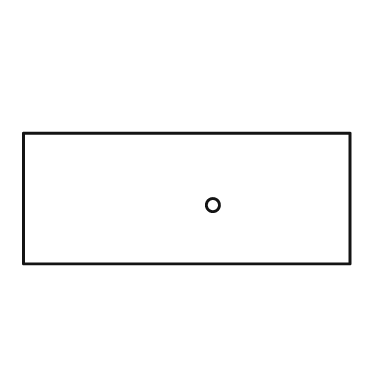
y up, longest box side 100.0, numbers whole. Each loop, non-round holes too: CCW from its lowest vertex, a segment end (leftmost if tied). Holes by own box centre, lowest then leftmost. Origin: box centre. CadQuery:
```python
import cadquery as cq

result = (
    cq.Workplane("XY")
    .moveTo(-50.0, -20.0)
    .lineTo(50.0, -20.0)
    .lineTo(50.0, 20.0)
    .lineTo(-50.0, 20.0)
    .close()
    .moveTo(8.0, -2.0)
    .circle(2.0)
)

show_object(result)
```